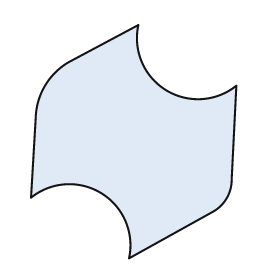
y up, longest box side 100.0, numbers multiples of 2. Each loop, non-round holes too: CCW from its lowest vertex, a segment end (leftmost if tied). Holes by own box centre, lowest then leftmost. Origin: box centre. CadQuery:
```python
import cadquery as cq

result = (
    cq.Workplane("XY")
    .moveTo(-2.0, -50.0)
    .lineTo(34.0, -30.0)
    .threePointArc((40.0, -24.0), (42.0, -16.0))
    .lineTo(44.0, 24.0)
    .threePointArc((14.0, 22.0), (2.0, 50.0))
    .lineTo(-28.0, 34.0)
    .threePointArc((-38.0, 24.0), (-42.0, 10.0))
    .lineTo(-44.0, -24.0)
    .threePointArc((-14.0, -22.0), (-2.0, -50.0))
    .close()
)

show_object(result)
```